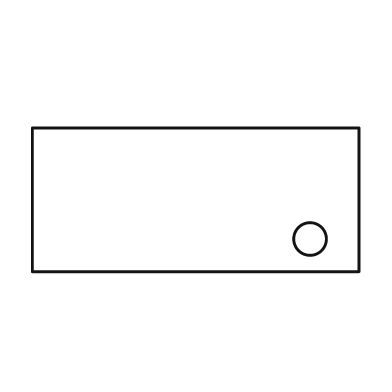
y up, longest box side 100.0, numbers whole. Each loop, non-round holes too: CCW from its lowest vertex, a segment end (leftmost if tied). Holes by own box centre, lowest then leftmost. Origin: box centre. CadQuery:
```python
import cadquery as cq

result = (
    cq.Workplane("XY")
    .moveTo(-50.0, -22.0)
    .lineTo(50.0, -22.0)
    .lineTo(50.0, 22.0)
    .lineTo(-50.0, 22.0)
    .close()
    .moveTo(35.0, -12.0)
    .circle(5.0)
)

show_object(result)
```